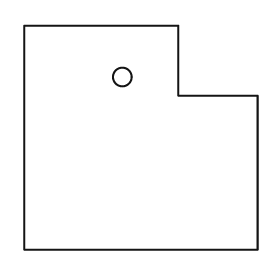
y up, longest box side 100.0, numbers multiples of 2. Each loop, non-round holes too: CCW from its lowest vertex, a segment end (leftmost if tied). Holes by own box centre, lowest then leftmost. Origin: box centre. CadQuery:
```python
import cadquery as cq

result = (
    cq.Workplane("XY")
    .moveTo(-50.0, -48.0)
    .lineTo(50.0, -48.0)
    .lineTo(50.0, 18.0)
    .lineTo(16.0, 18.0)
    .lineTo(16.0, 48.0)
    .lineTo(-50.0, 48.0)
    .close()
    .moveTo(-8.0, 26.0)
    .circle(4.0)
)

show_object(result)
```